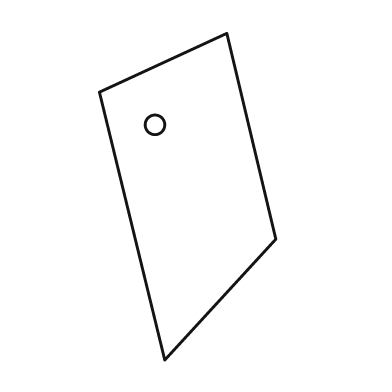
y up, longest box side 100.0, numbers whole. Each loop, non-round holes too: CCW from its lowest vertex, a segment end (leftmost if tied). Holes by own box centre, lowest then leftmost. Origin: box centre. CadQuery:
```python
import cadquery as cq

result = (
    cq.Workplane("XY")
    .moveTo(-7.0, -50.0)
    .lineTo(27.0, -13.0)
    .lineTo(12.0, 50.0)
    .lineTo(-27.0, 32.0)
    .close()
    .moveTo(-10.0, 22.0)
    .circle(3.0)
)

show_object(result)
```